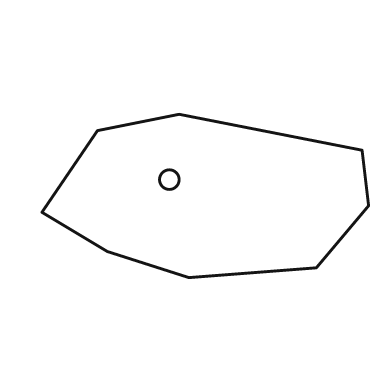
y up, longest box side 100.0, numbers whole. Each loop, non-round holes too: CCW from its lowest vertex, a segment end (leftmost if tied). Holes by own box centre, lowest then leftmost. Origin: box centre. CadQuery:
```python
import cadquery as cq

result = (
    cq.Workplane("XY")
    .moveTo(-5.0, -25.0)
    .lineTo(34.0, -22.0)
    .lineTo(50.0, -3.0)
    .lineTo(48.0, 14.0)
    .lineTo(-8.0, 25.0)
    .lineTo(-33.0, 20.0)
    .lineTo(-50.0, -5.0)
    .lineTo(-30.0, -17.0)
    .close()
    .moveTo(-11.0, 5.0)
    .circle(3.0)
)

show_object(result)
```